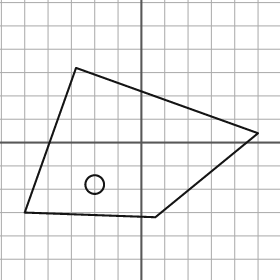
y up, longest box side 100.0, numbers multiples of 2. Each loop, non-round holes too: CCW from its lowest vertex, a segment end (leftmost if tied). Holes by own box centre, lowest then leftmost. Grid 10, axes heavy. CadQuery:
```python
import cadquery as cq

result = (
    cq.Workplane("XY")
    .moveTo(6.0, -32.0)
    .lineTo(50.0, 4.0)
    .lineTo(-28.0, 32.0)
    .lineTo(-50.0, -30.0)
    .close()
    .moveTo(-20.0, -18.0)
    .circle(4.0)
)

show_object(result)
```